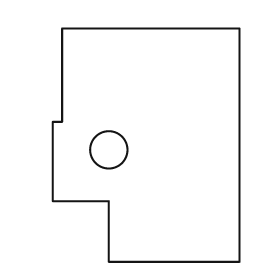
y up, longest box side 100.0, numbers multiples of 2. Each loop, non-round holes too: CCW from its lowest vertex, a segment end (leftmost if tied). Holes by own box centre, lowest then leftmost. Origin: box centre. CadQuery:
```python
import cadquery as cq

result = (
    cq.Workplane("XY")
    .moveTo(-16.0, -50.0)
    .lineTo(40.0, -50.0)
    .lineTo(40.0, 50.0)
    .lineTo(-36.0, 50.0)
    .lineTo(-36.0, 10.0)
    .lineTo(-40.0, 10.0)
    .lineTo(-40.0, -24.0)
    .lineTo(-16.0, -24.0)
    .close()
    .moveTo(-16.0, -2.0)
    .circle(8.0)
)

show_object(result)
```